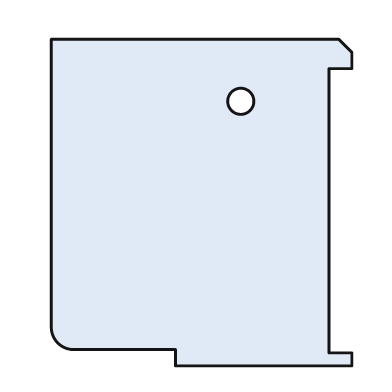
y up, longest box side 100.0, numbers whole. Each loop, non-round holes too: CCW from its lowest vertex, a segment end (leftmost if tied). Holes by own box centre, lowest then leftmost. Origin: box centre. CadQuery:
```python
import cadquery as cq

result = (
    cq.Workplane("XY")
    .moveTo(-8.0, -50.0)
    .lineTo(46.0, -50.0)
    .lineTo(46.0, -46.0)
    .lineTo(39.0, -46.0)
    .lineTo(39.0, 41.0)
    .lineTo(46.0, 41.0)
    .lineTo(46.0, 46.0)
    .lineTo(42.0, 50.0)
    .lineTo(-46.0, 50.0)
    .lineTo(-46.0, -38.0)
    .threePointArc((-44.0, -43.0), (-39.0, -45.0))
    .lineTo(-8.0, -45.0)
    .close()
    .moveTo(12.0, 31.0)
    .circle(4.0)
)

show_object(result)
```